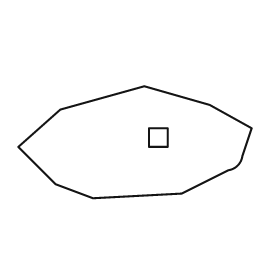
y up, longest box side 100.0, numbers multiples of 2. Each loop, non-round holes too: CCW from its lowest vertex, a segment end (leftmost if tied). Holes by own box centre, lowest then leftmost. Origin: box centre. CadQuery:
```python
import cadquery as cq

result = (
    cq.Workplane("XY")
    .moveTo(-18.0, -24.0)
    .lineTo(20.0, -22.0)
    .lineTo(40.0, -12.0)
    .threePointArc((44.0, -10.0), (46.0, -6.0))
    .lineTo(50.0, 6.0)
    .lineTo(32.0, 16.0)
    .lineTo(4.0, 24.0)
    .lineTo(-32.0, 14.0)
    .lineTo(-50.0, -2.0)
    .lineTo(-34.0, -18.0)
    .close()
    .moveTo(6.0, -2.0)
    .lineTo(14.0, -2.0)
    .lineTo(14.0, 6.0)
    .lineTo(6.0, 6.0)
    .close()
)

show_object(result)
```